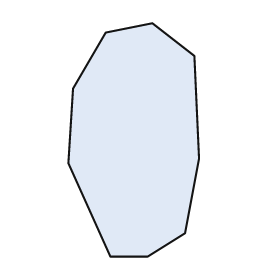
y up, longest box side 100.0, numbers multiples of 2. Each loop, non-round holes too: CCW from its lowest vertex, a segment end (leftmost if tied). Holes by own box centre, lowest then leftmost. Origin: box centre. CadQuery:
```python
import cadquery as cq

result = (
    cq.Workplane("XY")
    .moveTo(-10.0, -50.0)
    .lineTo(6.0, -50.0)
    .lineTo(22.0, -40.0)
    .lineTo(28.0, -8.0)
    .lineTo(26.0, 36.0)
    .lineTo(8.0, 50.0)
    .lineTo(-12.0, 46.0)
    .lineTo(-26.0, 22.0)
    .lineTo(-28.0, -10.0)
    .close()
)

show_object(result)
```